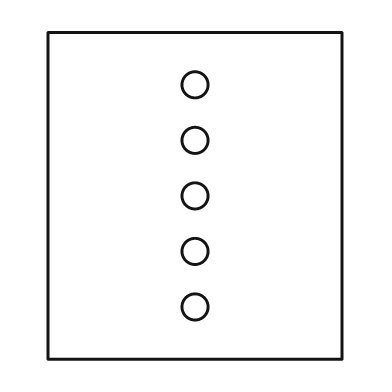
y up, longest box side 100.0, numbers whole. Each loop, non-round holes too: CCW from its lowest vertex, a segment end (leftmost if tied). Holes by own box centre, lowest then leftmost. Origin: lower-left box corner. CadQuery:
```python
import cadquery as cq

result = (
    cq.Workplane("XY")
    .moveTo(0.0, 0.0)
    .lineTo(90.0, 0.0)
    .lineTo(90.0, 100.0)
    .lineTo(0.0, 100.0)
    .close()
    .moveTo(45.0, 16.0)
    .circle(4.0)
    .moveTo(45.0, 33.0)
    .circle(4.0)
    .moveTo(45.0, 50.0)
    .circle(4.0)
    .moveTo(45.0, 67.0)
    .circle(4.0)
    .moveTo(45.0, 84.0)
    .circle(4.0)
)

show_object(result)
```